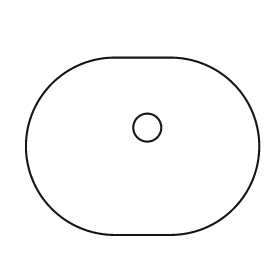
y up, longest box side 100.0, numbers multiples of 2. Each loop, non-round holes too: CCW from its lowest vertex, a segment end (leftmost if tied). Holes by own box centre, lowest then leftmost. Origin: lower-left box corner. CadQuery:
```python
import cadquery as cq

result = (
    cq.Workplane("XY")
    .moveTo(38.0, 0.0)
    .lineTo(62.0, 0.0)
    .threePointArc((100.0, 38.0), (62.0, 76.0))
    .lineTo(38.0, 76.0)
    .threePointArc((0.0, 38.0), (38.0, 0.0))
    .close()
    .moveTo(52.0, 46.0)
    .circle(6.0)
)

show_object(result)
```